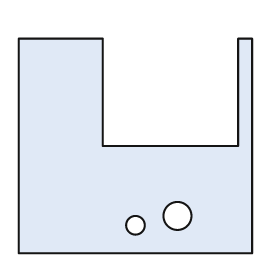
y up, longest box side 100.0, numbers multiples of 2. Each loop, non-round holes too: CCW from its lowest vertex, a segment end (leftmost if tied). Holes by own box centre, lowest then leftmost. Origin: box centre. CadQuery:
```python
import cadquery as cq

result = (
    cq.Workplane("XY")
    .moveTo(-50.0, -46.0)
    .lineTo(50.0, -46.0)
    .lineTo(50.0, 46.0)
    .lineTo(44.0, 46.0)
    .lineTo(44.0, 0.0)
    .lineTo(-14.0, 0.0)
    .lineTo(-14.0, 46.0)
    .lineTo(-50.0, 46.0)
    .close()
    .moveTo(0.0, -34.0)
    .circle(4.0)
    .moveTo(18.0, -30.0)
    .circle(6.0)
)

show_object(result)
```